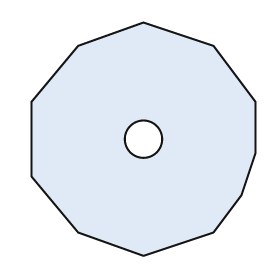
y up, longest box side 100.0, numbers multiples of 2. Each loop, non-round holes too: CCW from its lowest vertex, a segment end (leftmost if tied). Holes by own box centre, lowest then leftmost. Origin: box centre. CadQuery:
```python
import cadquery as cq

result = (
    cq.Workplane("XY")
    .moveTo(0.0, -50.0)
    .lineTo(30.0, -40.0)
    .lineTo(42.0, -24.0)
    .lineTo(48.0, -6.0)
    .lineTo(48.0, 16.0)
    .lineTo(30.0, 40.0)
    .lineTo(0.0, 50.0)
    .lineTo(-28.0, 40.0)
    .lineTo(-48.0, 16.0)
    .lineTo(-48.0, -16.0)
    .lineTo(-28.0, -40.0)
    .close()
    .moveTo(0.0, 0.0)
    .circle(8.0)
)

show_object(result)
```